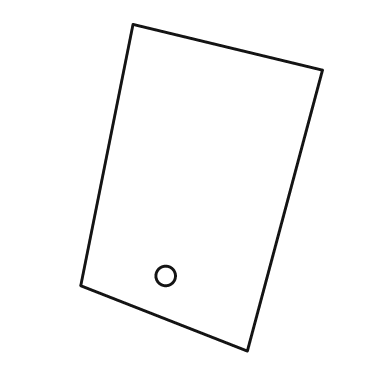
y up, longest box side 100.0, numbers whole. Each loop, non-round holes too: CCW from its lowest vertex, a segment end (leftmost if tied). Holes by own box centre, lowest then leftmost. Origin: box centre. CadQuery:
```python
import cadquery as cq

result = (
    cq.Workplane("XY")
    .moveTo(14.0, -50.0)
    .lineTo(37.0, 36.0)
    .lineTo(-21.0, 50.0)
    .lineTo(-37.0, -30.0)
    .close()
    .moveTo(-11.0, -27.0)
    .circle(3.0)
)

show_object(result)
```